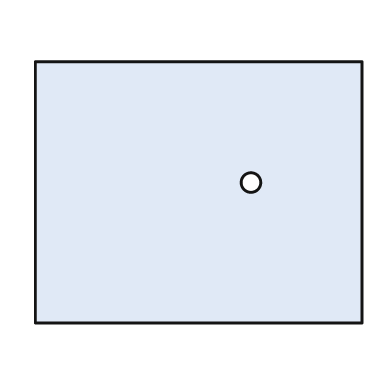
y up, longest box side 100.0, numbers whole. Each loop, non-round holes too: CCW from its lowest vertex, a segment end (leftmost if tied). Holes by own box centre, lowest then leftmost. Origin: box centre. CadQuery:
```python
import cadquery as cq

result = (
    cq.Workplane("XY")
    .moveTo(-50.0, -40.0)
    .lineTo(50.0, -40.0)
    .lineTo(50.0, 40.0)
    .lineTo(-50.0, 40.0)
    .close()
    .moveTo(16.0, 3.0)
    .circle(3.0)
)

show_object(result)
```